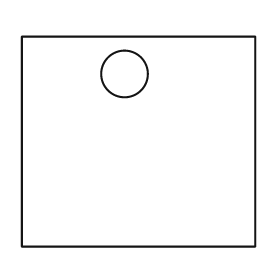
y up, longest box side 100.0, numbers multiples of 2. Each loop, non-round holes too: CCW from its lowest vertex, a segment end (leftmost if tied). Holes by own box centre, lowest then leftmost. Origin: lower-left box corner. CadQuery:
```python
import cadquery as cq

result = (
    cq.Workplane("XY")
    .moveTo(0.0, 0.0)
    .lineTo(100.0, 0.0)
    .lineTo(100.0, 90.0)
    .lineTo(0.0, 90.0)
    .close()
    .moveTo(44.0, 74.0)
    .circle(10.0)
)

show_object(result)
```